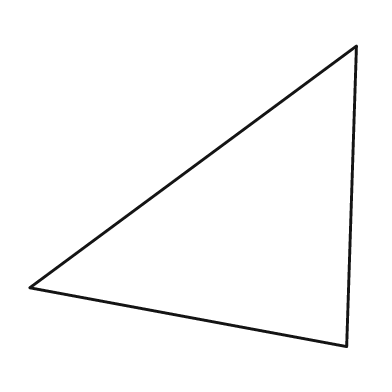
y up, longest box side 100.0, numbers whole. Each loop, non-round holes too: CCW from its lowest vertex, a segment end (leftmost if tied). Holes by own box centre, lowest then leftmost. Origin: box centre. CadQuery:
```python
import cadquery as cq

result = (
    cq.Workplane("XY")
    .moveTo(47.0, -46.0)
    .lineTo(50.0, 46.0)
    .lineTo(-50.0, -28.0)
    .close()
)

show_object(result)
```